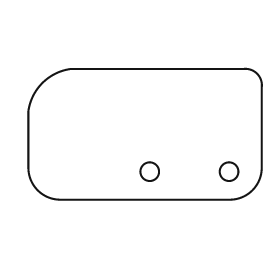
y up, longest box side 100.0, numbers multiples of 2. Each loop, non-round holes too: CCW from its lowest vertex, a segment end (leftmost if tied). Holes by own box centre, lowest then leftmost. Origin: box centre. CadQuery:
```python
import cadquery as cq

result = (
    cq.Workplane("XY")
    .moveTo(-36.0, -28.0)
    .lineTo(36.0, -28.0)
    .threePointArc((46.0, -24.0), (50.0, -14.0))
    .lineTo(50.0, 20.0)
    .threePointArc((48.0, 26.0), (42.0, 28.0))
    .lineTo(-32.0, 28.0)
    .threePointArc((-44.0, 22.0), (-50.0, 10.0))
    .lineTo(-50.0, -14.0)
    .threePointArc((-46.0, -24.0), (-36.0, -28.0))
    .close()
    .moveTo(2.0, -16.0)
    .circle(4.0)
    .moveTo(36.0, -16.0)
    .circle(4.0)
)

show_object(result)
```